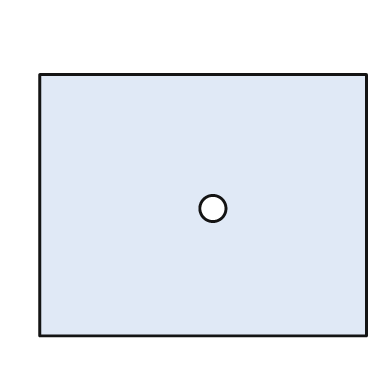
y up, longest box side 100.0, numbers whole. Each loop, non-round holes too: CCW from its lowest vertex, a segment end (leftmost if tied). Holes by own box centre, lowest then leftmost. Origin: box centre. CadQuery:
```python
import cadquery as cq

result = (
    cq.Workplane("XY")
    .moveTo(-50.0, -40.0)
    .lineTo(50.0, -40.0)
    .lineTo(50.0, 40.0)
    .lineTo(-50.0, 40.0)
    .close()
    .moveTo(3.0, -1.0)
    .circle(4.0)
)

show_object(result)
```